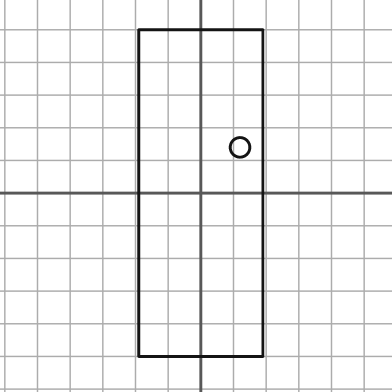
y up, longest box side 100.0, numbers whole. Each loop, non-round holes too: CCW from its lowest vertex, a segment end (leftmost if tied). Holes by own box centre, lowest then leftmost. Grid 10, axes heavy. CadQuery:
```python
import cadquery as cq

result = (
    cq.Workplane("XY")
    .moveTo(-19.0, -50.0)
    .lineTo(19.0, -50.0)
    .lineTo(19.0, 50.0)
    .lineTo(-19.0, 50.0)
    .close()
    .moveTo(12.0, 14.0)
    .circle(3.0)
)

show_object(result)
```